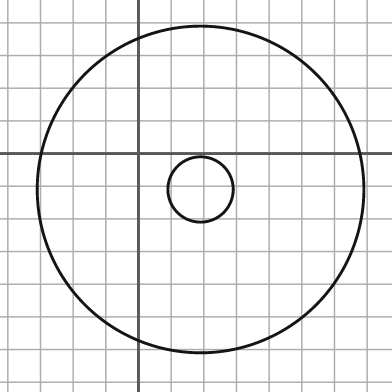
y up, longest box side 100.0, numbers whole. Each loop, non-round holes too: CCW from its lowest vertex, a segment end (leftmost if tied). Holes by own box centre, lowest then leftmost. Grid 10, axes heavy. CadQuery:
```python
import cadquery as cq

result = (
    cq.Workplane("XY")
    .moveTo(19.0, -11.0)
    .circle(50.0)
    .moveTo(19.0, -11.0)
    .circle(10.0)
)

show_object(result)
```